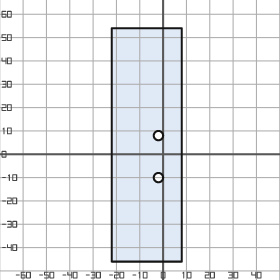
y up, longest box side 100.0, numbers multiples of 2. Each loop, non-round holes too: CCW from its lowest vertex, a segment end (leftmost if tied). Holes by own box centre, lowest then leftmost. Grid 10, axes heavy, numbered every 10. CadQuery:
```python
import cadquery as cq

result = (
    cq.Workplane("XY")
    .moveTo(-22.0, -46.0)
    .lineTo(8.0, -46.0)
    .lineTo(8.0, 54.0)
    .lineTo(-22.0, 54.0)
    .close()
    .moveTo(-2.0, -10.0)
    .circle(2.0)
    .moveTo(-2.0, 8.0)
    .circle(2.0)
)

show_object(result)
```